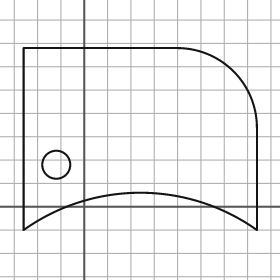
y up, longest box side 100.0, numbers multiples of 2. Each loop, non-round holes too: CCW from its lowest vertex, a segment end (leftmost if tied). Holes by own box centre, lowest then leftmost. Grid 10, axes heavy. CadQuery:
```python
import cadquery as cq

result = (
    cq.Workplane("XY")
    .moveTo(-26.0, -10.0)
    .threePointArc((24.0, 6.0), (74.0, -10.0))
    .lineTo(74.0, 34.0)
    .threePointArc((64.0, 58.0), (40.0, 68.0))
    .lineTo(-26.0, 68.0)
    .close()
    .moveTo(-12.0, 18.0)
    .circle(6.0)
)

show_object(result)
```